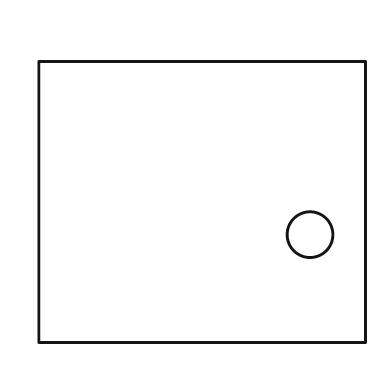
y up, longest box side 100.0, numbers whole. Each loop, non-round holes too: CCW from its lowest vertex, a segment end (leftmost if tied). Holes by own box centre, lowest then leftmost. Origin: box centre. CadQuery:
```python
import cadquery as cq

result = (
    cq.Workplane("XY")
    .moveTo(-50.0, -43.0)
    .lineTo(50.0, -43.0)
    .lineTo(50.0, 43.0)
    .lineTo(-50.0, 43.0)
    .close()
    .moveTo(33.0, -10.0)
    .circle(7.0)
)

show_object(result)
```